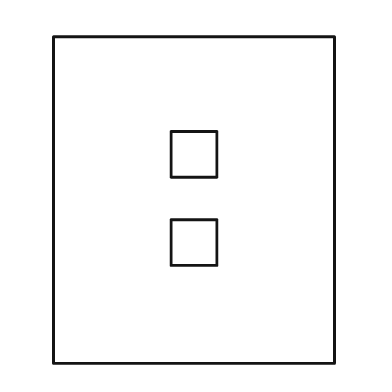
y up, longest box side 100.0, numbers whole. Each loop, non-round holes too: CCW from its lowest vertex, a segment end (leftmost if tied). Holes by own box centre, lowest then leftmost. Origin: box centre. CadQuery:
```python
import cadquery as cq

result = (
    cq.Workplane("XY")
    .moveTo(-43.0, -50.0)
    .lineTo(43.0, -50.0)
    .lineTo(43.0, 50.0)
    .lineTo(-43.0, 50.0)
    .close()
    .moveTo(-7.0, -20.0)
    .lineTo(7.0, -20.0)
    .lineTo(7.0, -6.0)
    .lineTo(-7.0, -6.0)
    .close()
    .moveTo(-7.0, 7.0)
    .lineTo(7.0, 7.0)
    .lineTo(7.0, 21.0)
    .lineTo(-7.0, 21.0)
    .close()
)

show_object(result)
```